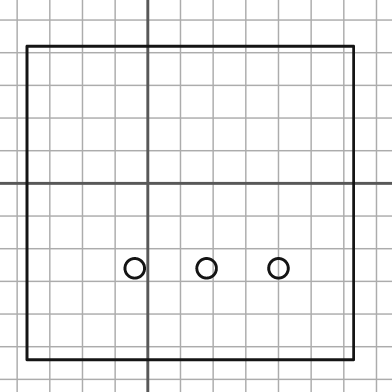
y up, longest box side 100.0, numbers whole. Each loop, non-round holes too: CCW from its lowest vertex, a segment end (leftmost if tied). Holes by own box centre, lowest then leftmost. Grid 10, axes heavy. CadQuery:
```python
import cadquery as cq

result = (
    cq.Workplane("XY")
    .moveTo(-37.0, -54.0)
    .lineTo(63.0, -54.0)
    .lineTo(63.0, 42.0)
    .lineTo(-37.0, 42.0)
    .close()
    .moveTo(-4.0, -26.0)
    .circle(3.0)
    .moveTo(18.0, -26.0)
    .circle(3.0)
    .moveTo(40.0, -26.0)
    .circle(3.0)
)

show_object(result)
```